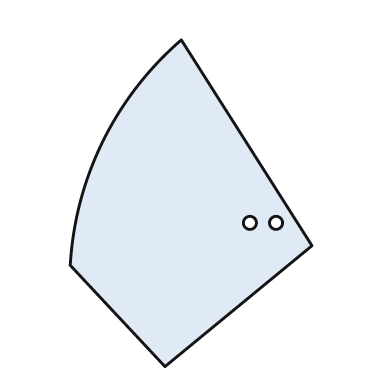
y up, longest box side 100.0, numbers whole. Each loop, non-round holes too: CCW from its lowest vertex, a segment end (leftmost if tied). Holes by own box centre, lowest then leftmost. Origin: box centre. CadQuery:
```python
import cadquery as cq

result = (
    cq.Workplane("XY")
    .moveTo(-8.0, -50.0)
    .lineTo(37.0, -13.0)
    .lineTo(-3.0, 50.0)
    .threePointArc((-27.0, 19.0), (-37.0, -19.0))
    .close()
    .moveTo(18.0, -6.0)
    .circle(2.0)
    .moveTo(26.0, -6.0)
    .circle(2.0)
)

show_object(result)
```